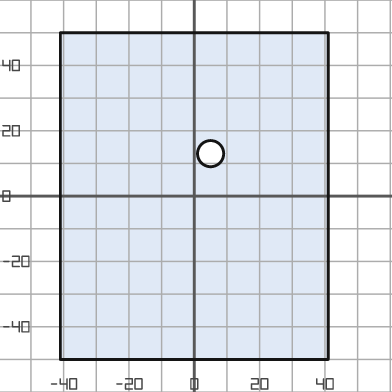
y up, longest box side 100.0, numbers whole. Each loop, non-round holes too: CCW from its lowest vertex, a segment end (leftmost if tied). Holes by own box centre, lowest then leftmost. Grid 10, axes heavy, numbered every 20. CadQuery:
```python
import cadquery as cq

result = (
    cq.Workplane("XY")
    .moveTo(-41.0, -50.0)
    .lineTo(41.0, -50.0)
    .lineTo(41.0, 50.0)
    .lineTo(-41.0, 50.0)
    .close()
    .moveTo(5.0, 13.0)
    .circle(4.0)
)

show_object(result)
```